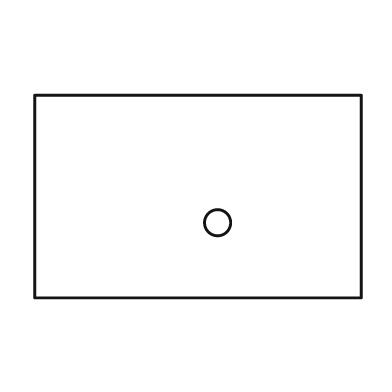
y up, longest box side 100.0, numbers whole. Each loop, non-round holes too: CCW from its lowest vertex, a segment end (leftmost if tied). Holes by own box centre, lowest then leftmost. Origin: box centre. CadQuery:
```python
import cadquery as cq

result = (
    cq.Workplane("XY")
    .moveTo(-50.0, -31.0)
    .lineTo(50.0, -31.0)
    .lineTo(50.0, 31.0)
    .lineTo(-50.0, 31.0)
    .close()
    .moveTo(6.0, -8.0)
    .circle(4.0)
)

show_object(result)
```